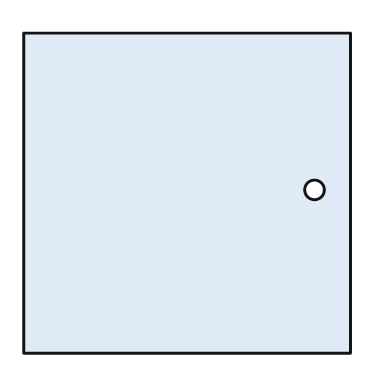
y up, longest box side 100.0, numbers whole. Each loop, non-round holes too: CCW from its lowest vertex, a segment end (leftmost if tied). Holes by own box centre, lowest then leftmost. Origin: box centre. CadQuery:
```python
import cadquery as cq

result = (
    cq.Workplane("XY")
    .moveTo(-50.0, -49.0)
    .lineTo(50.0, -49.0)
    .lineTo(50.0, 49.0)
    .lineTo(-50.0, 49.0)
    .close()
    .moveTo(39.0, 1.0)
    .circle(3.0)
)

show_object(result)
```